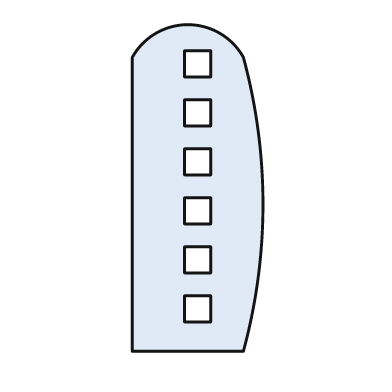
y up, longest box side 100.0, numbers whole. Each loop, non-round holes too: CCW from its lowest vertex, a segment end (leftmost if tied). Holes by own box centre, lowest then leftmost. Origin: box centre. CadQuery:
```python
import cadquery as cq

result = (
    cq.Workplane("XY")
    .moveTo(-20.0, -50.0)
    .lineTo(14.0, -50.0)
    .threePointArc((20.0, -5.0), (14.0, 40.0))
    .threePointArc((-3.0, 50.0), (-20.0, 40.0))
    .close()
    .moveTo(-4.0, -41.0)
    .lineTo(4.0, -41.0)
    .lineTo(4.0, -33.0)
    .lineTo(-4.0, -33.0)
    .close()
    .moveTo(-4.0, -26.0)
    .lineTo(4.0, -26.0)
    .lineTo(4.0, -18.0)
    .lineTo(-4.0, -18.0)
    .close()
    .moveTo(-4.0, -11.0)
    .lineTo(4.0, -11.0)
    .lineTo(4.0, -3.0)
    .lineTo(-4.0, -3.0)
    .close()
    .moveTo(-4.0, 4.0)
    .lineTo(4.0, 4.0)
    .lineTo(4.0, 12.0)
    .lineTo(-4.0, 12.0)
    .close()
    .moveTo(-4.0, 19.0)
    .lineTo(4.0, 19.0)
    .lineTo(4.0, 27.0)
    .lineTo(-4.0, 27.0)
    .close()
    .moveTo(-4.0, 34.0)
    .lineTo(4.0, 34.0)
    .lineTo(4.0, 42.0)
    .lineTo(-4.0, 42.0)
    .close()
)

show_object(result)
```